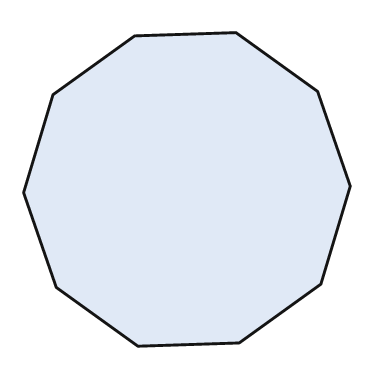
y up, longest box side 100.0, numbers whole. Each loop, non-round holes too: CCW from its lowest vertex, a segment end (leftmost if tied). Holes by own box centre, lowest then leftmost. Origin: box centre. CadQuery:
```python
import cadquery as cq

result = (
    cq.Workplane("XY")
    .moveTo(-15.0, -48.0)
    .lineTo(16.0, -47.0)
    .lineTo(41.0, -29.0)
    .lineTo(50.0, 1.0)
    .lineTo(40.0, 30.0)
    .lineTo(15.0, 48.0)
    .lineTo(-16.0, 47.0)
    .lineTo(-41.0, 29.0)
    .lineTo(-50.0, -1.0)
    .lineTo(-40.0, -30.0)
    .close()
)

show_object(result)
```